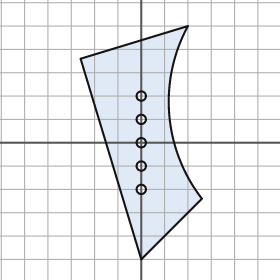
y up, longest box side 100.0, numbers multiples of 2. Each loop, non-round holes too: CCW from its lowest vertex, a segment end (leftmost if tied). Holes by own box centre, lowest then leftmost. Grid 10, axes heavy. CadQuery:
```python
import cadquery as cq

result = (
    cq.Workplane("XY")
    .moveTo(0.0, -50.0)
    .lineTo(26.0, -24.0)
    .threePointArc((12.0, 12.0), (20.0, 50.0))
    .lineTo(-26.0, 36.0)
    .close()
    .moveTo(0.0, -20.0)
    .circle(2.0)
    .moveTo(0.0, -10.0)
    .circle(2.0)
    .moveTo(0.0, 0.0)
    .circle(2.0)
    .moveTo(0.0, 10.0)
    .circle(2.0)
    .moveTo(0.0, 20.0)
    .circle(2.0)
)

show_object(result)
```